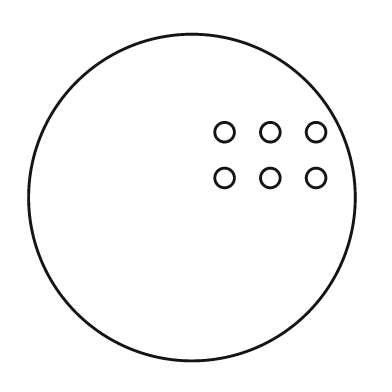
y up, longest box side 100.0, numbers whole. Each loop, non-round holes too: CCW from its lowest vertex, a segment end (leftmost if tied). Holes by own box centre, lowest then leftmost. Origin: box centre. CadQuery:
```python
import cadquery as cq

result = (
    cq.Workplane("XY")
    .moveTo(0.0, 0.0)
    .circle(50.0)
    .moveTo(10.0, 6.0)
    .circle(3.0)
    .moveTo(24.0, 6.0)
    .circle(3.0)
    .moveTo(38.0, 6.0)
    .circle(3.0)
    .moveTo(10.0, 20.0)
    .circle(3.0)
    .moveTo(24.0, 20.0)
    .circle(3.0)
    .moveTo(38.0, 20.0)
    .circle(3.0)
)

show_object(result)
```